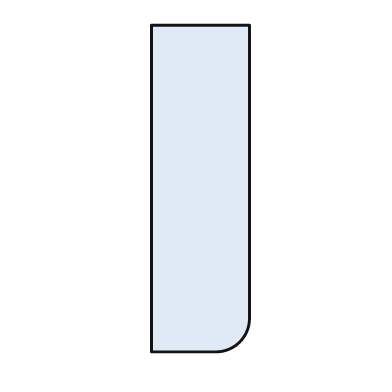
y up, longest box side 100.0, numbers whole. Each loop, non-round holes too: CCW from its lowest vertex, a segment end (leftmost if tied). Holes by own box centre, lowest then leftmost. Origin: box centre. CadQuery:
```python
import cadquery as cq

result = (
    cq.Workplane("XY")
    .moveTo(-15.0, -50.0)
    .lineTo(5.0, -50.0)
    .threePointArc((12.0, -47.0), (15.0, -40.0))
    .lineTo(15.0, 50.0)
    .lineTo(-15.0, 50.0)
    .close()
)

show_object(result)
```